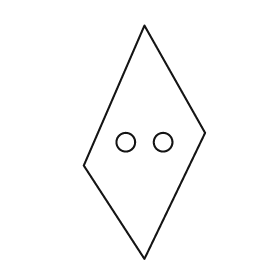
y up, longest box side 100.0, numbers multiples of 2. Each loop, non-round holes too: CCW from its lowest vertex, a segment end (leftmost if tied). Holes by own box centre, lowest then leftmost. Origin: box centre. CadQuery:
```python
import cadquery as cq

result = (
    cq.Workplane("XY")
    .moveTo(0.0, -50.0)
    .lineTo(26.0, 4.0)
    .lineTo(0.0, 50.0)
    .lineTo(-26.0, -10.0)
    .close()
    .moveTo(-8.0, 0.0)
    .circle(4.0)
    .moveTo(8.0, 0.0)
    .circle(4.0)
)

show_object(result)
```